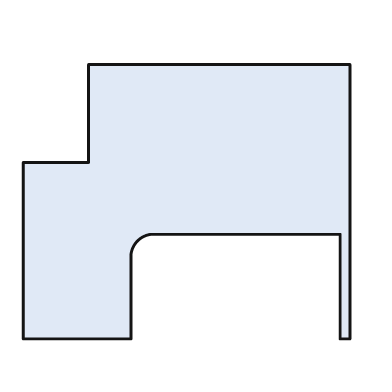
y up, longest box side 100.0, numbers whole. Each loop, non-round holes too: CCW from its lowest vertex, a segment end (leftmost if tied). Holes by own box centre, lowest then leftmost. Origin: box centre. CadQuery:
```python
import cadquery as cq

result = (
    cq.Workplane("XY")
    .moveTo(-50.0, -42.0)
    .lineTo(-17.0, -42.0)
    .lineTo(-17.0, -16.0)
    .threePointArc((-15.0, -12.0), (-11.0, -10.0))
    .lineTo(47.0, -10.0)
    .lineTo(47.0, -42.0)
    .lineTo(50.0, -42.0)
    .lineTo(50.0, 42.0)
    .lineTo(-30.0, 42.0)
    .lineTo(-30.0, 12.0)
    .lineTo(-50.0, 12.0)
    .close()
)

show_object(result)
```